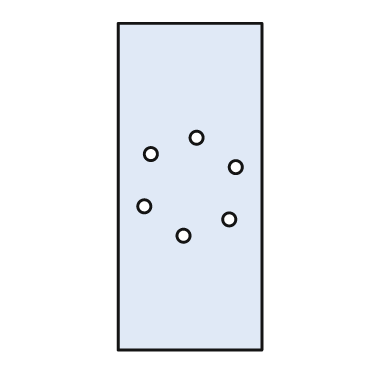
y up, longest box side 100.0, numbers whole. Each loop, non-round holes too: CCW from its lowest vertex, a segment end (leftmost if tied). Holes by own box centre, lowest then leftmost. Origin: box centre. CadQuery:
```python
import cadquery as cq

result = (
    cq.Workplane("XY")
    .moveTo(-22.0, -50.0)
    .lineTo(22.0, -50.0)
    .lineTo(22.0, 50.0)
    .lineTo(-22.0, 50.0)
    .close()
    .moveTo(-2.0, -15.0)
    .circle(2.0)
    .moveTo(12.0, -10.0)
    .circle(2.0)
    .moveTo(-14.0, -6.0)
    .circle(2.0)
    .moveTo(14.0, 6.0)
    .circle(2.0)
    .moveTo(-12.0, 10.0)
    .circle(2.0)
    .moveTo(2.0, 15.0)
    .circle(2.0)
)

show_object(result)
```